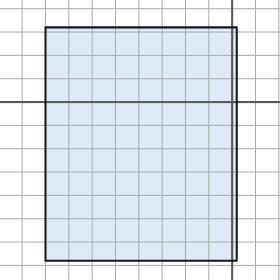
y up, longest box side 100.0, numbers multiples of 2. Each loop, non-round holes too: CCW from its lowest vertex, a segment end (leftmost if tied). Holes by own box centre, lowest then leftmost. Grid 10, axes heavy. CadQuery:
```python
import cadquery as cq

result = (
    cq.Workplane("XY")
    .moveTo(-80.0, -68.0)
    .lineTo(2.0, -68.0)
    .lineTo(2.0, 32.0)
    .lineTo(-80.0, 32.0)
    .close()
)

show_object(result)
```